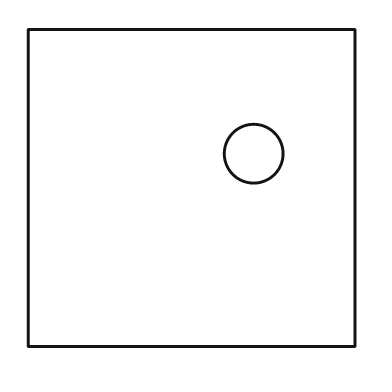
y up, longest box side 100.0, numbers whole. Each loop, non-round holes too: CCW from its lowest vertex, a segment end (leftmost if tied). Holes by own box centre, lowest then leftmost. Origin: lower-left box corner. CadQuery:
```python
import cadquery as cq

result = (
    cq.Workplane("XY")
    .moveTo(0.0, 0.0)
    .lineTo(100.0, 0.0)
    .lineTo(100.0, 97.0)
    .lineTo(0.0, 97.0)
    .close()
    .moveTo(69.0, 59.0)
    .circle(9.0)
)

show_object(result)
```